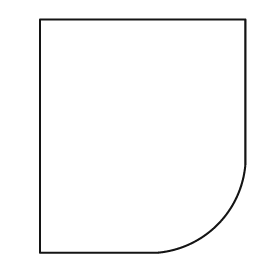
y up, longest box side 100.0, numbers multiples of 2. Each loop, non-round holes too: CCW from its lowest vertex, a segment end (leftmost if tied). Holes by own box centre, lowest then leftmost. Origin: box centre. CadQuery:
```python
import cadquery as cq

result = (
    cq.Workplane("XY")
    .moveTo(-44.0, -50.0)
    .lineTo(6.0, -50.0)
    .threePointArc((32.0, -38.0), (44.0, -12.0))
    .lineTo(44.0, 50.0)
    .lineTo(-44.0, 50.0)
    .close()
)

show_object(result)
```